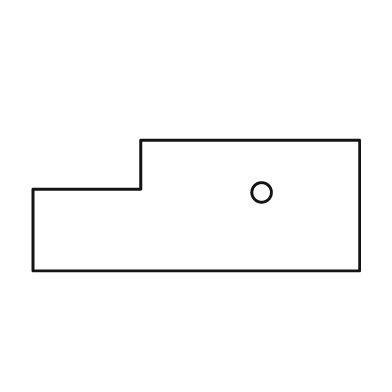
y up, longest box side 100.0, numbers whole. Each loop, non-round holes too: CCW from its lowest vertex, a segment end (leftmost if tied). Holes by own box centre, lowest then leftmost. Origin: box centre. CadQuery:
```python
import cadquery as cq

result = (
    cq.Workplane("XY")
    .moveTo(-50.0, -20.0)
    .lineTo(50.0, -20.0)
    .lineTo(50.0, 20.0)
    .lineTo(-17.0, 20.0)
    .lineTo(-17.0, 5.0)
    .lineTo(-50.0, 5.0)
    .close()
    .moveTo(20.0, 4.0)
    .circle(3.0)
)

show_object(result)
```